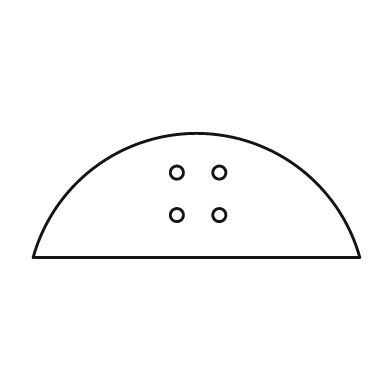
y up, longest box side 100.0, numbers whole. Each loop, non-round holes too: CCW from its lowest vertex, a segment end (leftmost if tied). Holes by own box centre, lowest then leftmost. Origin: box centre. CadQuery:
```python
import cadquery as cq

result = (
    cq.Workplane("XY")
    .moveTo(-50.0, -19.0)
    .lineTo(50.0, -19.0)
    .threePointArc((0.0, 19.0), (-50.0, -19.0))
    .close()
    .moveTo(-6.0, -6.0)
    .circle(2.0)
    .moveTo(7.0, -6.0)
    .circle(2.0)
    .moveTo(-6.0, 7.0)
    .circle(2.0)
    .moveTo(7.0, 7.0)
    .circle(2.0)
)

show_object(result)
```